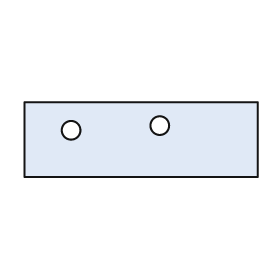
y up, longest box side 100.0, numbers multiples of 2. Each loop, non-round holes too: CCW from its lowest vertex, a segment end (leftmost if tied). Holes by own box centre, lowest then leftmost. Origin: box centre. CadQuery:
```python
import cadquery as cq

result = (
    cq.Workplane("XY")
    .moveTo(-50.0, -16.0)
    .lineTo(50.0, -16.0)
    .lineTo(50.0, 16.0)
    .lineTo(-50.0, 16.0)
    .close()
    .moveTo(-30.0, 4.0)
    .circle(4.0)
    .moveTo(8.0, 6.0)
    .circle(4.0)
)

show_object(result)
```